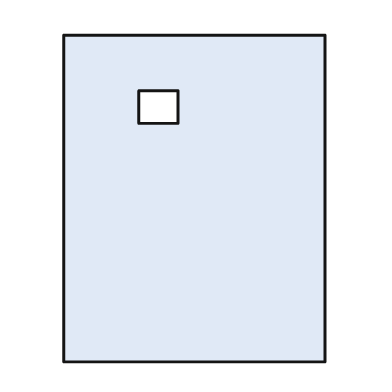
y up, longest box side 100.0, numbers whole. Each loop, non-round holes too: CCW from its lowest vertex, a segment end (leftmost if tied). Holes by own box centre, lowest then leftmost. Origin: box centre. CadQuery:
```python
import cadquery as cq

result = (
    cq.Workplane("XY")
    .moveTo(-40.0, -50.0)
    .lineTo(40.0, -50.0)
    .lineTo(40.0, 50.0)
    .lineTo(-40.0, 50.0)
    .close()
    .moveTo(-17.0, 23.0)
    .lineTo(-5.0, 23.0)
    .lineTo(-5.0, 33.0)
    .lineTo(-17.0, 33.0)
    .close()
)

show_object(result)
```